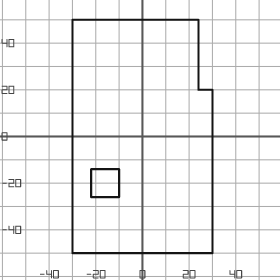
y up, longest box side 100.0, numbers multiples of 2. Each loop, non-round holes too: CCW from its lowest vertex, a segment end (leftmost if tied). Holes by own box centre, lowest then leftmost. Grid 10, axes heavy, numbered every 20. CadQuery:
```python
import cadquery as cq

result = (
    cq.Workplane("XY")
    .moveTo(-30.0, -50.0)
    .lineTo(30.0, -50.0)
    .lineTo(30.0, 20.0)
    .lineTo(24.0, 20.0)
    .lineTo(24.0, 50.0)
    .lineTo(-30.0, 50.0)
    .close()
    .moveTo(-22.0, -26.0)
    .lineTo(-10.0, -26.0)
    .lineTo(-10.0, -14.0)
    .lineTo(-22.0, -14.0)
    .close()
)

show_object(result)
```